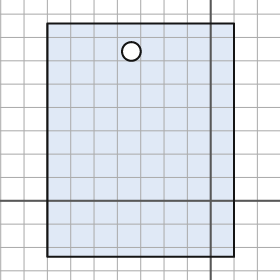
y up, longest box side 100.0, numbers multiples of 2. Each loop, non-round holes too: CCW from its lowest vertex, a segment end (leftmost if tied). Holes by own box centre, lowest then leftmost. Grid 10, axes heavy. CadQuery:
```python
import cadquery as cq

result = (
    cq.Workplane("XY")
    .moveTo(-70.0, -24.0)
    .lineTo(10.0, -24.0)
    .lineTo(10.0, 76.0)
    .lineTo(-70.0, 76.0)
    .close()
    .moveTo(-34.0, 64.0)
    .circle(4.0)
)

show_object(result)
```